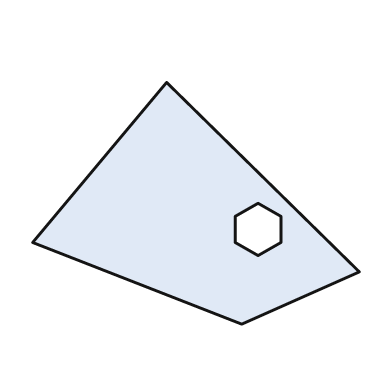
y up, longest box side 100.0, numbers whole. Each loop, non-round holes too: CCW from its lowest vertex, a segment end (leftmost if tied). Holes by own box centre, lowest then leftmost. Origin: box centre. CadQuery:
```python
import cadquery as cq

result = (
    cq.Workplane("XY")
    .moveTo(14.0, -37.0)
    .lineTo(50.0, -21.0)
    .lineTo(-9.0, 37.0)
    .lineTo(-50.0, -12.0)
    .close()
    .moveTo(19.0, -16.0)
    .lineTo(26.0, -12.0)
    .lineTo(26.0, -4.0)
    .lineTo(19.0, 0.0)
    .lineTo(12.0, -4.0)
    .lineTo(12.0, -12.0)
    .close()
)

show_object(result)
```